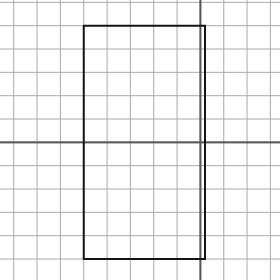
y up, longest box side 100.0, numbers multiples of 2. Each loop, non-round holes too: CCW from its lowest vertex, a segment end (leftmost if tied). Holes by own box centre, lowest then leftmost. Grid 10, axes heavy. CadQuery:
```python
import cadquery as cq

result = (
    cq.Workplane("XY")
    .moveTo(-50.0, -50.0)
    .lineTo(2.0, -50.0)
    .lineTo(2.0, 50.0)
    .lineTo(-50.0, 50.0)
    .close()
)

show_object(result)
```